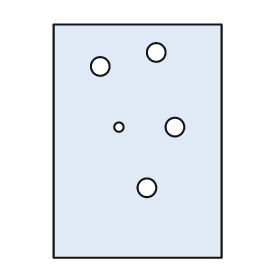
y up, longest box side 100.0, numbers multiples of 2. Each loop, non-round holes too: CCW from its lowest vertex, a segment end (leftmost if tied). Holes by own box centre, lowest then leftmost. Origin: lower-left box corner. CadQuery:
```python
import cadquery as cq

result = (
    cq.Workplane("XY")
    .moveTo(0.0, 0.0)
    .lineTo(72.0, 0.0)
    .lineTo(72.0, 100.0)
    .lineTo(0.0, 100.0)
    .close()
    .moveTo(40.0, 30.0)
    .circle(4.0)
    .moveTo(28.0, 56.0)
    .circle(2.0)
    .moveTo(52.0, 56.0)
    .circle(4.0)
    .moveTo(20.0, 82.0)
    .circle(4.0)
    .moveTo(44.0, 88.0)
    .circle(4.0)
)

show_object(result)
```